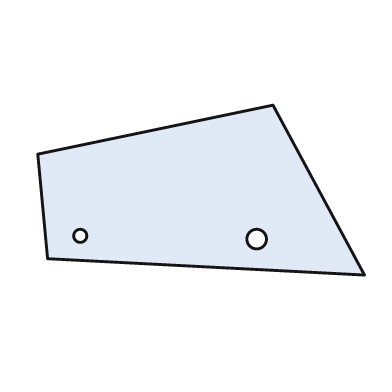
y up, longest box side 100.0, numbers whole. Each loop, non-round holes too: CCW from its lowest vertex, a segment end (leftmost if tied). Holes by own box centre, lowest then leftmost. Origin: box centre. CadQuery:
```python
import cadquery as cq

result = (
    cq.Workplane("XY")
    .moveTo(50.0, -26.0)
    .lineTo(22.0, 26.0)
    .lineTo(-50.0, 11.0)
    .lineTo(-47.0, -21.0)
    .close()
    .moveTo(17.0, -15.0)
    .circle(3.0)
    .moveTo(-37.0, -14.0)
    .circle(2.0)
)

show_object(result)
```